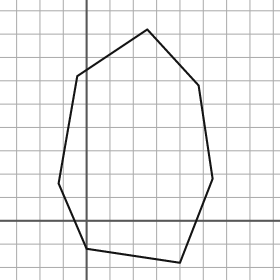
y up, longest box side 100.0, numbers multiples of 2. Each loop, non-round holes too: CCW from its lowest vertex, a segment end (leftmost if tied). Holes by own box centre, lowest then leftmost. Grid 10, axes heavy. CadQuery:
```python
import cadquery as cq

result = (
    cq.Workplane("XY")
    .moveTo(40.0, -18.0)
    .lineTo(54.0, 18.0)
    .lineTo(48.0, 58.0)
    .lineTo(26.0, 82.0)
    .lineTo(-4.0, 62.0)
    .lineTo(-12.0, 16.0)
    .lineTo(0.0, -12.0)
    .close()
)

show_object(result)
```